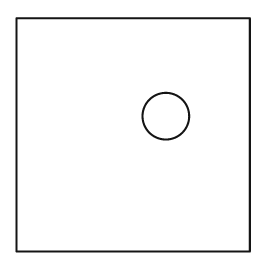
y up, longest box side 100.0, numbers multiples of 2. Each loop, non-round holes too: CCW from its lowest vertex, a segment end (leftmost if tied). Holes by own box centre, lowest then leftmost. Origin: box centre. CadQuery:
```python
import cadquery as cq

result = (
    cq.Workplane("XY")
    .moveTo(-50.0, -50.0)
    .lineTo(50.0, -50.0)
    .lineTo(50.0, 50.0)
    .lineTo(-50.0, 50.0)
    .close()
    .moveTo(14.0, 8.0)
    .circle(10.0)
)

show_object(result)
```